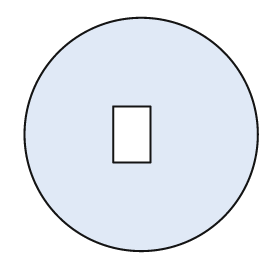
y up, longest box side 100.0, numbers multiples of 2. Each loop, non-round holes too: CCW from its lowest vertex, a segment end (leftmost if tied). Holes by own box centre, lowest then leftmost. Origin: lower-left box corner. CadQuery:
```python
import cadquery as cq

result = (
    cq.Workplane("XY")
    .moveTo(50.0, 50.0)
    .circle(50.0)
    .moveTo(38.0, 38.0)
    .lineTo(54.0, 38.0)
    .lineTo(54.0, 62.0)
    .lineTo(38.0, 62.0)
    .close()
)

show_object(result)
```